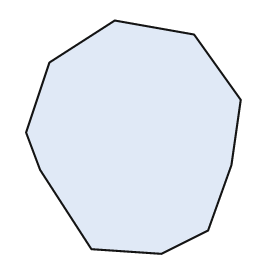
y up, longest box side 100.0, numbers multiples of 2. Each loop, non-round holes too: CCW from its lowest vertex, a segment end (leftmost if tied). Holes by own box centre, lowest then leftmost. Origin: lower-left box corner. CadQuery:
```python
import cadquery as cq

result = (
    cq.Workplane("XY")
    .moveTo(58.0, 0.0)
    .lineTo(78.0, 10.0)
    .lineTo(88.0, 38.0)
    .lineTo(92.0, 66.0)
    .lineTo(72.0, 94.0)
    .lineTo(38.0, 100.0)
    .lineTo(10.0, 82.0)
    .lineTo(0.0, 52.0)
    .lineTo(6.0, 36.0)
    .lineTo(28.0, 2.0)
    .close()
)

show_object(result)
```